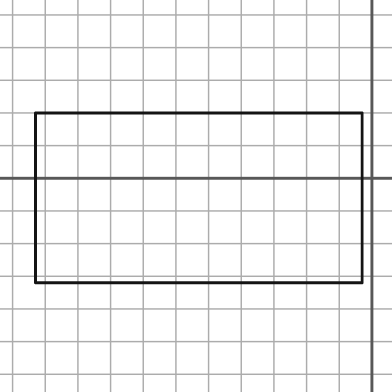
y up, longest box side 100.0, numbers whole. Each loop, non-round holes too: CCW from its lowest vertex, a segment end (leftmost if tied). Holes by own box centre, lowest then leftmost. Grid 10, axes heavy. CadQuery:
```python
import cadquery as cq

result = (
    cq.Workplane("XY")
    .moveTo(-103.0, -32.0)
    .lineTo(-3.0, -32.0)
    .lineTo(-3.0, 20.0)
    .lineTo(-103.0, 20.0)
    .close()
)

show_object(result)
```